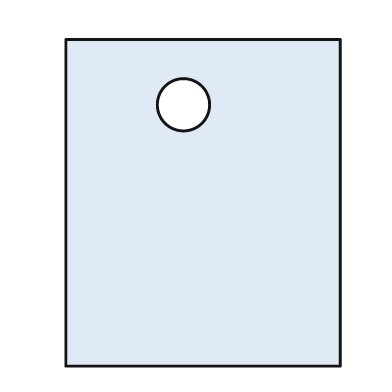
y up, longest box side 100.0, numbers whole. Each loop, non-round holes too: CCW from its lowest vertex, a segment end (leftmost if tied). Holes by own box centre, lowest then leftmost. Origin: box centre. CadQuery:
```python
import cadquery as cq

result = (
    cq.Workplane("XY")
    .moveTo(-42.0, -50.0)
    .lineTo(42.0, -50.0)
    .lineTo(42.0, 50.0)
    .lineTo(-42.0, 50.0)
    .close()
    .moveTo(-6.0, 30.0)
    .circle(8.0)
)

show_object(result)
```